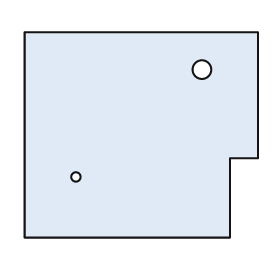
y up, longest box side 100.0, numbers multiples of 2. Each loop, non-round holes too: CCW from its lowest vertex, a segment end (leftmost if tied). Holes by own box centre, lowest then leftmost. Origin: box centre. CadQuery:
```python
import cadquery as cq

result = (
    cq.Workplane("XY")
    .moveTo(-50.0, -44.0)
    .lineTo(38.0, -44.0)
    .lineTo(38.0, -10.0)
    .lineTo(50.0, -10.0)
    .lineTo(50.0, 44.0)
    .lineTo(-50.0, 44.0)
    .close()
    .moveTo(-28.0, -18.0)
    .circle(2.0)
    .moveTo(26.0, 28.0)
    .circle(4.0)
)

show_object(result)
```